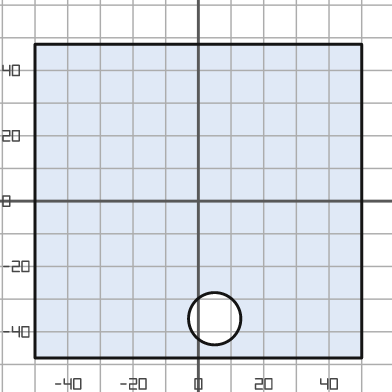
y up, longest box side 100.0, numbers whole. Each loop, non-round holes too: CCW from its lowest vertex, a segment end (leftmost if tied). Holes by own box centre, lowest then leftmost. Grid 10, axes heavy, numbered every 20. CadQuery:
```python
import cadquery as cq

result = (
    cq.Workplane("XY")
    .moveTo(-50.0, -48.0)
    .lineTo(50.0, -48.0)
    .lineTo(50.0, 48.0)
    .lineTo(-50.0, 48.0)
    .close()
    .moveTo(5.0, -36.0)
    .circle(8.0)
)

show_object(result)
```